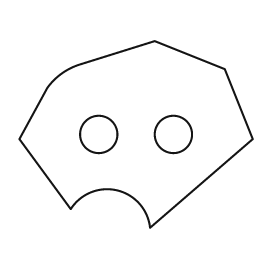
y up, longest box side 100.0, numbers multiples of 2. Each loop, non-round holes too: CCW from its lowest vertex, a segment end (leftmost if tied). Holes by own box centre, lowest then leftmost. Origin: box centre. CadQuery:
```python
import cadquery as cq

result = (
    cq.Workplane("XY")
    .moveTo(6.0, -40.0)
    .lineTo(50.0, -2.0)
    .lineTo(38.0, 28.0)
    .lineTo(8.0, 40.0)
    .lineTo(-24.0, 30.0)
    .threePointArc((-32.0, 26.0), (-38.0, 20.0))
    .lineTo(-50.0, -2.0)
    .lineTo(-28.0, -32.0)
    .threePointArc((-8.0, -24.0), (6.0, -40.0))
    .close()
    .moveTo(-16.0, 0.0)
    .circle(8.0)
    .moveTo(16.0, 0.0)
    .circle(8.0)
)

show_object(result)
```